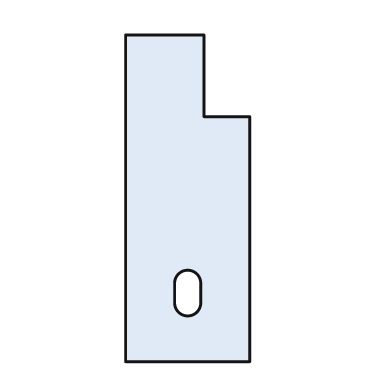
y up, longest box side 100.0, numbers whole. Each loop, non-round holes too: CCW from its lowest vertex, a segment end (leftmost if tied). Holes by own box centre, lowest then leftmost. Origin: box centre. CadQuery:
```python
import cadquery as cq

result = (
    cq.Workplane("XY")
    .moveTo(-19.0, -50.0)
    .lineTo(19.0, -50.0)
    .lineTo(19.0, 25.0)
    .lineTo(5.0, 25.0)
    .lineTo(5.0, 50.0)
    .lineTo(-19.0, 50.0)
    .close()
    .moveTo(-4.0, -32.0)
    .threePointArc((0.0, -36.0), (4.0, -32.0))
    .lineTo(4.0, -26.0)
    .threePointArc((0.0, -22.0), (-4.0, -26.0))
    .close()
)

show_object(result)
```